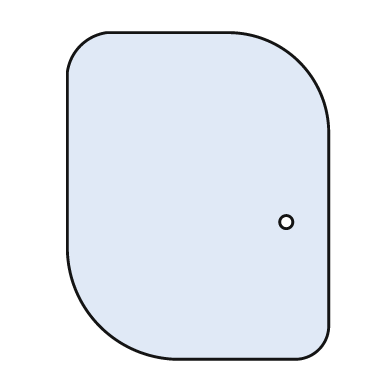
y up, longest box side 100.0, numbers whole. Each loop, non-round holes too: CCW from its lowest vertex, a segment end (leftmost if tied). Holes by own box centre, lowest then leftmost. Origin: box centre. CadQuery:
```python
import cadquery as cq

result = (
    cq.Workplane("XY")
    .moveTo(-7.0, -50.0)
    .lineTo(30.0, -50.0)
    .threePointArc((37.0, -47.0), (40.0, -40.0))
    .lineTo(40.0, 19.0)
    .threePointArc((31.0, 41.0), (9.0, 50.0))
    .lineTo(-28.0, 50.0)
    .threePointArc((-36.0, 46.0), (-40.0, 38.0))
    .lineTo(-40.0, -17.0)
    .threePointArc((-30.0, -40.0), (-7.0, -50.0))
    .close()
    .moveTo(27.0, -8.0)
    .circle(2.0)
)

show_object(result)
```